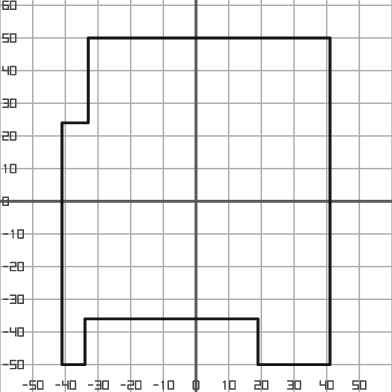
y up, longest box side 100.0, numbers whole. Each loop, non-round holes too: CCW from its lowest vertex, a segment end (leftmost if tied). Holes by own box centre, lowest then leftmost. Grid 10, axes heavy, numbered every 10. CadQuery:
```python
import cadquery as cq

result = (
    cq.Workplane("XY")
    .moveTo(-41.0, -50.0)
    .lineTo(-34.0, -50.0)
    .lineTo(-34.0, -36.0)
    .lineTo(19.0, -36.0)
    .lineTo(19.0, -50.0)
    .lineTo(41.0, -50.0)
    .lineTo(41.0, 50.0)
    .lineTo(-33.0, 50.0)
    .lineTo(-33.0, 24.0)
    .lineTo(-41.0, 24.0)
    .close()
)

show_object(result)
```